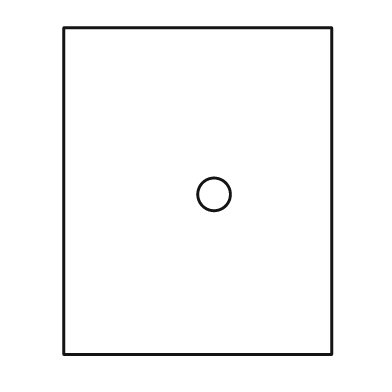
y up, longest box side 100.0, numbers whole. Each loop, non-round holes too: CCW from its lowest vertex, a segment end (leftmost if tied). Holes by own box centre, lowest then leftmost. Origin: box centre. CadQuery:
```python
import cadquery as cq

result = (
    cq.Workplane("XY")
    .moveTo(-41.0, -50.0)
    .lineTo(41.0, -50.0)
    .lineTo(41.0, 50.0)
    .lineTo(-41.0, 50.0)
    .close()
    .moveTo(5.0, -1.0)
    .circle(5.0)
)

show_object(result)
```